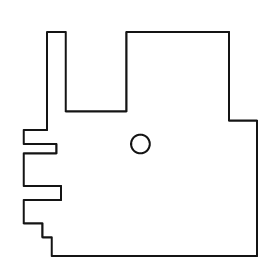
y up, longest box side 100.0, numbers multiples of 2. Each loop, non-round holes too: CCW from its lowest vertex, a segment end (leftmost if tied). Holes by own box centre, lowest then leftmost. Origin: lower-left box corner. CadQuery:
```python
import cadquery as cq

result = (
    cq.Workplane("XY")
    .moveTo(12.0, 0.0)
    .lineTo(100.0, 0.0)
    .lineTo(100.0, 58.0)
    .lineTo(88.0, 58.0)
    .lineTo(88.0, 96.0)
    .lineTo(44.0, 96.0)
    .lineTo(44.0, 62.0)
    .lineTo(18.0, 62.0)
    .lineTo(18.0, 96.0)
    .lineTo(10.0, 96.0)
    .lineTo(10.0, 54.0)
    .lineTo(0.0, 54.0)
    .lineTo(0.0, 48.0)
    .lineTo(14.0, 48.0)
    .lineTo(14.0, 44.0)
    .lineTo(0.0, 44.0)
    .lineTo(0.0, 30.0)
    .lineTo(16.0, 30.0)
    .lineTo(16.0, 24.0)
    .lineTo(0.0, 24.0)
    .lineTo(0.0, 14.0)
    .lineTo(8.0, 14.0)
    .lineTo(8.0, 8.0)
    .lineTo(12.0, 8.0)
    .close()
    .moveTo(50.0, 48.0)
    .circle(4.0)
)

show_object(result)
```